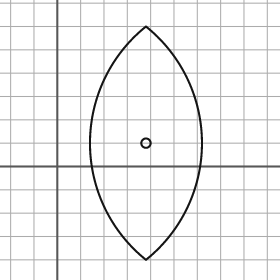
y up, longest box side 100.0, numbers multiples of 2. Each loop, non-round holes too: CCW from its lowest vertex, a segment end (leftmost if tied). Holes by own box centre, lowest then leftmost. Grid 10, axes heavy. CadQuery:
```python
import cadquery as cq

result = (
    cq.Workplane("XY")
    .moveTo(38.0, -40.0)
    .threePointArc((62.0, 10.0), (38.0, 60.0))
    .threePointArc((14.0, 10.0), (38.0, -40.0))
    .close()
    .moveTo(38.0, 10.0)
    .circle(2.0)
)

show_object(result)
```